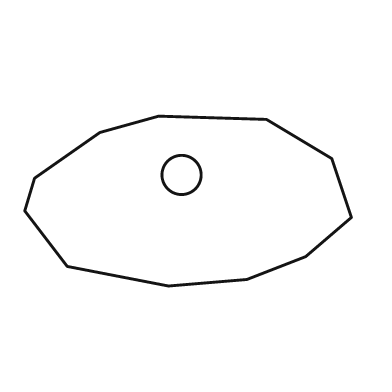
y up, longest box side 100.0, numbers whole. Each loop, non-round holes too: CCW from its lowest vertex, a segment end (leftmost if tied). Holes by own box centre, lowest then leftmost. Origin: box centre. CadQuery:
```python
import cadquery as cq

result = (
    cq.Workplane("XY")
    .moveTo(-6.0, -26.0)
    .lineTo(18.0, -24.0)
    .lineTo(36.0, -17.0)
    .lineTo(50.0, -5.0)
    .lineTo(44.0, 13.0)
    .lineTo(24.0, 25.0)
    .lineTo(-9.0, 26.0)
    .lineTo(-27.0, 21.0)
    .lineTo(-47.0, 7.0)
    .lineTo(-50.0, -3.0)
    .lineTo(-37.0, -20.0)
    .close()
    .moveTo(-2.0, 8.0)
    .circle(6.0)
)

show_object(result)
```